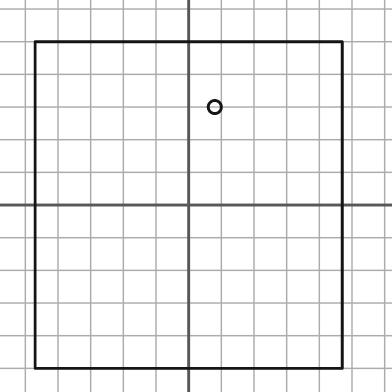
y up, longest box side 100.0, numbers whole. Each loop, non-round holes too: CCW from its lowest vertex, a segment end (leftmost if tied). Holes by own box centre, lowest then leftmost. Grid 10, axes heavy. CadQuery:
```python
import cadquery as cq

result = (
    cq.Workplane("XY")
    .moveTo(-47.0, -50.0)
    .lineTo(47.0, -50.0)
    .lineTo(47.0, 50.0)
    .lineTo(-47.0, 50.0)
    .close()
    .moveTo(8.0, 30.0)
    .circle(2.0)
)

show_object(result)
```